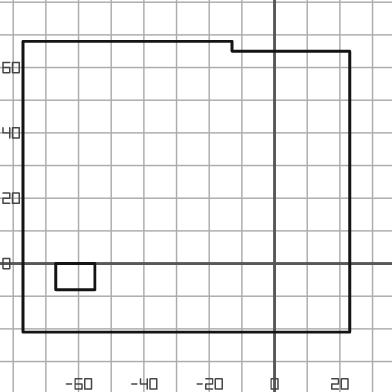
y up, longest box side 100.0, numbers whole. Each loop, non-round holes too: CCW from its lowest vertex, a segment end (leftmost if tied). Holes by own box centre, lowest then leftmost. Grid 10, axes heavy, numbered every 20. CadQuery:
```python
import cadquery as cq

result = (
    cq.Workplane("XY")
    .moveTo(-77.0, -21.0)
    .lineTo(23.0, -21.0)
    .lineTo(23.0, 65.0)
    .lineTo(-13.0, 65.0)
    .lineTo(-13.0, 68.0)
    .lineTo(-77.0, 68.0)
    .close()
    .moveTo(-67.0, -8.0)
    .lineTo(-55.0, -8.0)
    .lineTo(-55.0, 0.0)
    .lineTo(-67.0, 0.0)
    .close()
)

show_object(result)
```